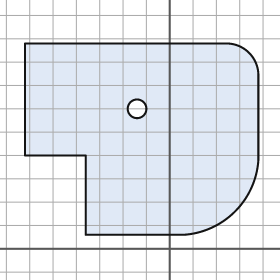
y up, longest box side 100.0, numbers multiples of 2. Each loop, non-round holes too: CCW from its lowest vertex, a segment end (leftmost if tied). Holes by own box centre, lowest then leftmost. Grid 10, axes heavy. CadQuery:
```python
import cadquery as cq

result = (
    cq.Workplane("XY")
    .moveTo(-36.0, 6.0)
    .lineTo(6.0, 6.0)
    .threePointArc((28.0, 16.0), (38.0, 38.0))
    .lineTo(38.0, 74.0)
    .threePointArc((34.0, 84.0), (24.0, 88.0))
    .lineTo(-62.0, 88.0)
    .lineTo(-62.0, 40.0)
    .lineTo(-36.0, 40.0)
    .close()
    .moveTo(-14.0, 60.0)
    .circle(4.0)
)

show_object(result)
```